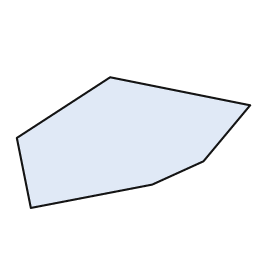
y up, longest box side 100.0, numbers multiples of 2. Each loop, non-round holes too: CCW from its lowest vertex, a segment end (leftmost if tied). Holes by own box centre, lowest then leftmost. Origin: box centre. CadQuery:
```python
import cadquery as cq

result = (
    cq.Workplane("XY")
    .moveTo(-44.0, -28.0)
    .lineTo(8.0, -18.0)
    .lineTo(30.0, -8.0)
    .lineTo(50.0, 16.0)
    .lineTo(-10.0, 28.0)
    .lineTo(-50.0, 2.0)
    .close()
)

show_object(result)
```